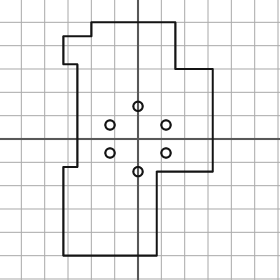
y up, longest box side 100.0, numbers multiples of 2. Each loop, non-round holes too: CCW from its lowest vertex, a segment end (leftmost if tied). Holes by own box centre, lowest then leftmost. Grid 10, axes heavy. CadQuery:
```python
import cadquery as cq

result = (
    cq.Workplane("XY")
    .moveTo(-32.0, -50.0)
    .lineTo(8.0, -50.0)
    .lineTo(8.0, -14.0)
    .lineTo(32.0, -14.0)
    .lineTo(32.0, 30.0)
    .lineTo(16.0, 30.0)
    .lineTo(16.0, 50.0)
    .lineTo(-20.0, 50.0)
    .lineTo(-20.0, 44.0)
    .lineTo(-32.0, 44.0)
    .lineTo(-32.0, 32.0)
    .lineTo(-26.0, 32.0)
    .lineTo(-26.0, -12.0)
    .lineTo(-32.0, -12.0)
    .close()
    .moveTo(0.0, -14.0)
    .circle(2.0)
    .moveTo(-12.0, -6.0)
    .circle(2.0)
    .moveTo(12.0, -6.0)
    .circle(2.0)
    .moveTo(-12.0, 6.0)
    .circle(2.0)
    .moveTo(12.0, 6.0)
    .circle(2.0)
    .moveTo(0.0, 14.0)
    .circle(2.0)
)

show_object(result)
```